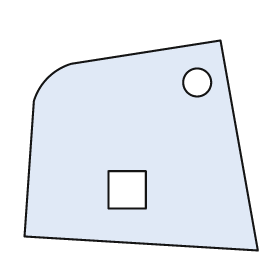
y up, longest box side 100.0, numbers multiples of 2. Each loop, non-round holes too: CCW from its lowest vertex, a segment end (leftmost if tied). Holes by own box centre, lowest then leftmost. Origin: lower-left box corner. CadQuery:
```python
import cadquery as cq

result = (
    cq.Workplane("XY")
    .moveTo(100.0, 0.0)
    .lineTo(84.0, 90.0)
    .lineTo(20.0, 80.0)
    .threePointArc((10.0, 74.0), (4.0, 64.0))
    .lineTo(0.0, 6.0)
    .close()
    .moveTo(36.0, 18.0)
    .lineTo(52.0, 18.0)
    .lineTo(52.0, 34.0)
    .lineTo(36.0, 34.0)
    .close()
    .moveTo(74.0, 72.0)
    .circle(6.0)
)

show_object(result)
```